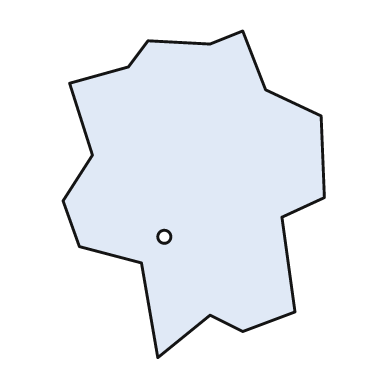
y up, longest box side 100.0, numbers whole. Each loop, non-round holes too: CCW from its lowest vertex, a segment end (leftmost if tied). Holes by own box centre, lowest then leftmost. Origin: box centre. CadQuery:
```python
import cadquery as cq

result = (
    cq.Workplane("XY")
    .moveTo(-11.0, -50.0)
    .lineTo(5.0, -37.0)
    .lineTo(15.0, -42.0)
    .lineTo(31.0, -36.0)
    .lineTo(27.0, -7.0)
    .lineTo(40.0, -1.0)
    .lineTo(39.0, 24.0)
    .lineTo(22.0, 32.0)
    .lineTo(15.0, 50.0)
    .lineTo(5.0, 46.0)
    .lineTo(-14.0, 47.0)
    .lineTo(-20.0, 39.0)
    .lineTo(-38.0, 34.0)
    .lineTo(-31.0, 12.0)
    .lineTo(-40.0, -2.0)
    .lineTo(-35.0, -16.0)
    .lineTo(-16.0, -21.0)
    .close()
    .moveTo(-9.0, -13.0)
    .circle(2.0)
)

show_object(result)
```